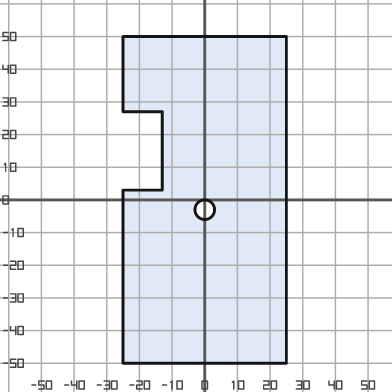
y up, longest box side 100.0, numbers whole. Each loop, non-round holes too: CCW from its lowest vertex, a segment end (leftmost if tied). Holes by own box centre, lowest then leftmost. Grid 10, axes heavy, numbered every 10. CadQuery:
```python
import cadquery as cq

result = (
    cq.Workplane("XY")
    .moveTo(-25.0, -50.0)
    .lineTo(25.0, -50.0)
    .lineTo(25.0, 50.0)
    .lineTo(-25.0, 50.0)
    .lineTo(-25.0, 27.0)
    .lineTo(-13.0, 27.0)
    .lineTo(-13.0, 3.0)
    .lineTo(-25.0, 3.0)
    .close()
    .moveTo(0.0, -3.0)
    .circle(3.0)
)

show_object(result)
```